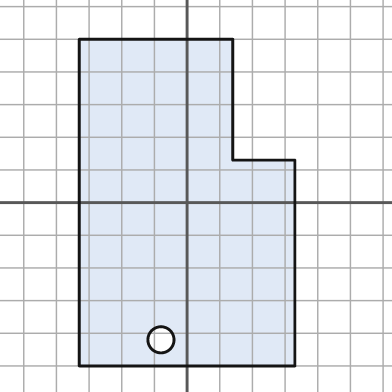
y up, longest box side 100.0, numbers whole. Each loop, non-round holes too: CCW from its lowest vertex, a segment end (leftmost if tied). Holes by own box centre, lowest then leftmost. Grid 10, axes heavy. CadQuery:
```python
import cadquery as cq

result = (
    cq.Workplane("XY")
    .moveTo(-33.0, -50.0)
    .lineTo(33.0, -50.0)
    .lineTo(33.0, 13.0)
    .lineTo(14.0, 13.0)
    .lineTo(14.0, 50.0)
    .lineTo(-33.0, 50.0)
    .close()
    .moveTo(-8.0, -42.0)
    .circle(4.0)
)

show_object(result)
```